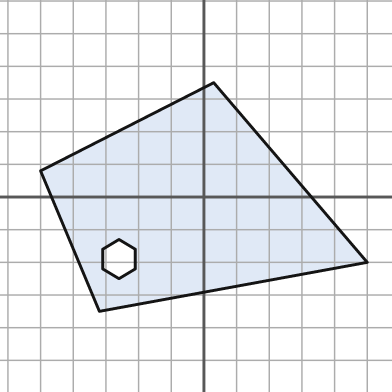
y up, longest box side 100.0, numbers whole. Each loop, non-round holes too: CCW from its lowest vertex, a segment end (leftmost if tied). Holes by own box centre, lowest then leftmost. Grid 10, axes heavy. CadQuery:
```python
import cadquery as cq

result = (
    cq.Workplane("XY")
    .moveTo(-32.0, -35.0)
    .lineTo(50.0, -20.0)
    .lineTo(3.0, 35.0)
    .lineTo(-50.0, 8.0)
    .close()
    .moveTo(-26.0, -25.0)
    .lineTo(-21.0, -22.0)
    .lineTo(-21.0, -16.0)
    .lineTo(-26.0, -13.0)
    .lineTo(-31.0, -16.0)
    .lineTo(-31.0, -22.0)
    .close()
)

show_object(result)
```